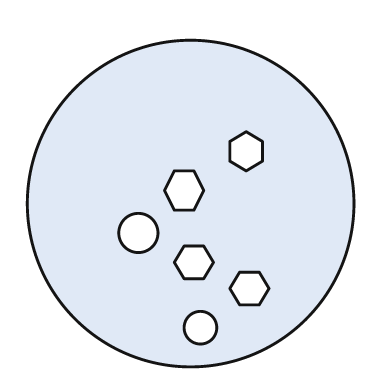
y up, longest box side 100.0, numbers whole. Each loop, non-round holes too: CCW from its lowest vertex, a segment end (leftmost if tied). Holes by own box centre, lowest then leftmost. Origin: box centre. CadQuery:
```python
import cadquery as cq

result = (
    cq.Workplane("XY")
    .moveTo(0.0, 0.0)
    .circle(50.0)
    .moveTo(3.0, -38.0)
    .circle(5.0)
    .moveTo(15.0, -31.0)
    .lineTo(21.0, -31.0)
    .lineTo(24.0, -26.0)
    .lineTo(21.0, -21.0)
    .lineTo(15.0, -21.0)
    .lineTo(12.0, -26.0)
    .close()
    .moveTo(-2.0, -23.0)
    .lineTo(4.0, -23.0)
    .lineTo(7.0, -18.0)
    .lineTo(4.0, -13.0)
    .lineTo(-2.0, -13.0)
    .lineTo(-5.0, -18.0)
    .close()
    .moveTo(-16.0, -9.0)
    .circle(6.0)
    .moveTo(-5.0, -2.0)
    .lineTo(1.0, -2.0)
    .lineTo(4.0, 4.0)
    .lineTo(1.0, 10.0)
    .lineTo(-5.0, 10.0)
    .lineTo(-8.0, 4.0)
    .close()
    .moveTo(17.0, 10.0)
    .lineTo(22.0, 13.0)
    .lineTo(22.0, 19.0)
    .lineTo(17.0, 22.0)
    .lineTo(12.0, 19.0)
    .lineTo(12.0, 13.0)
    .close()
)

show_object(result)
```